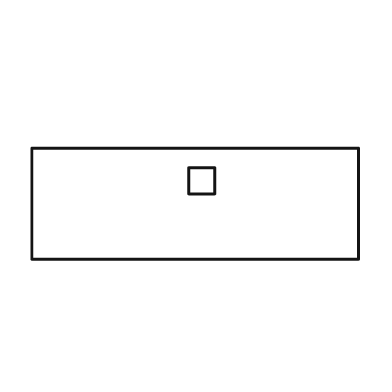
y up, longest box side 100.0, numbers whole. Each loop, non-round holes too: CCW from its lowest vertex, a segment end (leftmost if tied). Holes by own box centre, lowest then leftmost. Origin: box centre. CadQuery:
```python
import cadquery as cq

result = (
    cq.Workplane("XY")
    .moveTo(-50.0, -17.0)
    .lineTo(50.0, -17.0)
    .lineTo(50.0, 17.0)
    .lineTo(-50.0, 17.0)
    .close()
    .moveTo(-2.0, 3.0)
    .lineTo(6.0, 3.0)
    .lineTo(6.0, 11.0)
    .lineTo(-2.0, 11.0)
    .close()
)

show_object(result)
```